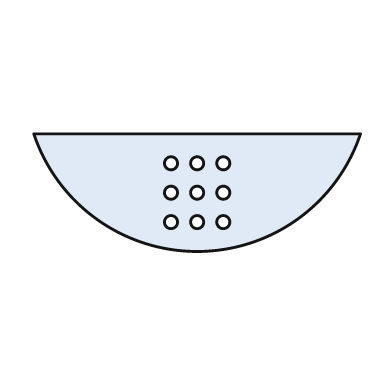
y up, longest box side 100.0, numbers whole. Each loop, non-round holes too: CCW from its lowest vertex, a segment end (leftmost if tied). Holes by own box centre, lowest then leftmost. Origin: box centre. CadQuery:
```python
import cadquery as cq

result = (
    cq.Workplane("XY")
    .moveTo(-50.0, 18.0)
    .threePointArc((0.0, -18.0), (50.0, 18.0))
    .close()
    .moveTo(-8.0, -9.0)
    .circle(2.0)
    .moveTo(0.0, -9.0)
    .circle(2.0)
    .moveTo(8.0, -9.0)
    .circle(2.0)
    .moveTo(-8.0, 0.0)
    .circle(2.0)
    .moveTo(0.0, 0.0)
    .circle(2.0)
    .moveTo(8.0, 0.0)
    .circle(2.0)
    .moveTo(-8.0, 9.0)
    .circle(2.0)
    .moveTo(0.0, 9.0)
    .circle(2.0)
    .moveTo(8.0, 9.0)
    .circle(2.0)
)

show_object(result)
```